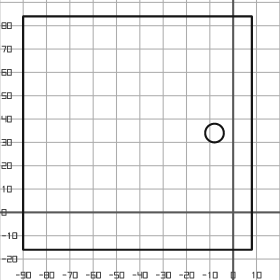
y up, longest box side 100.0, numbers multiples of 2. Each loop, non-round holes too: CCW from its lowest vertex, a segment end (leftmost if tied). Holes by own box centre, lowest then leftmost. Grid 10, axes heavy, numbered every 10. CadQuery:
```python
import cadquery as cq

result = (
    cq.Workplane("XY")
    .moveTo(-90.0, -16.0)
    .lineTo(8.0, -16.0)
    .lineTo(8.0, 84.0)
    .lineTo(-90.0, 84.0)
    .close()
    .moveTo(-8.0, 34.0)
    .circle(4.0)
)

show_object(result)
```